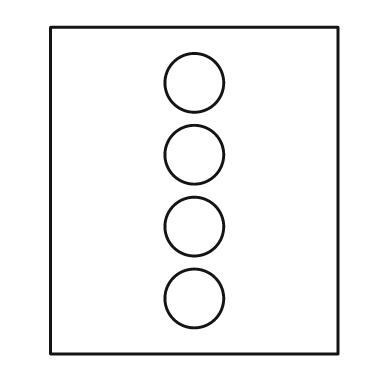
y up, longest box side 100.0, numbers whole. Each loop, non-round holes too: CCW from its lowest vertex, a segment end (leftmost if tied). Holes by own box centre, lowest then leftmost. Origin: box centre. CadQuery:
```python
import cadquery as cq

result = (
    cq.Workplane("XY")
    .moveTo(-44.0, -50.0)
    .lineTo(44.0, -50.0)
    .lineTo(44.0, 50.0)
    .lineTo(-44.0, 50.0)
    .close()
    .moveTo(0.0, -33.0)
    .circle(9.0)
    .moveTo(0.0, -11.0)
    .circle(9.0)
    .moveTo(0.0, 11.0)
    .circle(9.0)
    .moveTo(0.0, 33.0)
    .circle(9.0)
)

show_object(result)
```